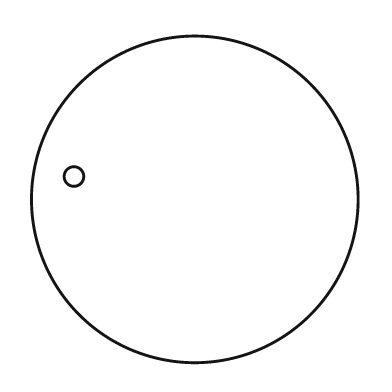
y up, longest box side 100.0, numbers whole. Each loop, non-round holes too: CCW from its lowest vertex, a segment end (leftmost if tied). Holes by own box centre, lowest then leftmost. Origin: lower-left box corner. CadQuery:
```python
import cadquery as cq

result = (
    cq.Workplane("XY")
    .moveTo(50.0, 50.0)
    .circle(50.0)
    .moveTo(13.0, 57.0)
    .circle(3.0)
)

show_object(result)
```